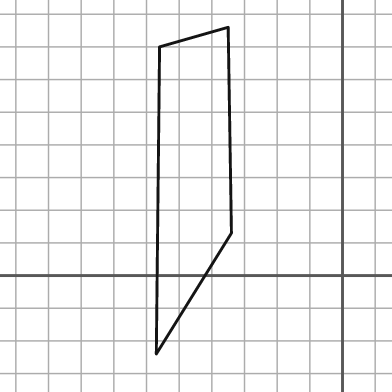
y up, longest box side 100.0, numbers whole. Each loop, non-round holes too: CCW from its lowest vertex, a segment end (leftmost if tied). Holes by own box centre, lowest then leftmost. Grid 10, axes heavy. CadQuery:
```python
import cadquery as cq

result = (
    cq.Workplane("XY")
    .moveTo(-57.0, -24.0)
    .lineTo(-34.0, 13.0)
    .lineTo(-35.0, 76.0)
    .lineTo(-56.0, 70.0)
    .close()
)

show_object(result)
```